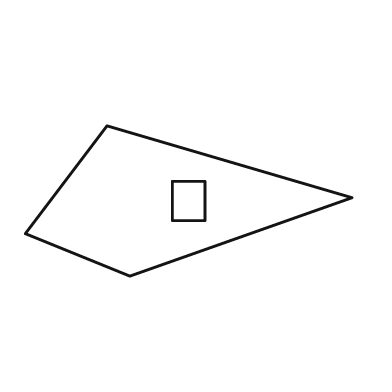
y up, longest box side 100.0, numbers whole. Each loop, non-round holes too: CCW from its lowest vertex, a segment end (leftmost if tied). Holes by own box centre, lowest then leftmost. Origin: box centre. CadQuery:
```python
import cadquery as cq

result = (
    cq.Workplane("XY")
    .moveTo(-18.0, -23.0)
    .lineTo(50.0, 1.0)
    .lineTo(-25.0, 23.0)
    .lineTo(-50.0, -10.0)
    .close()
    .moveTo(-5.0, -6.0)
    .lineTo(5.0, -6.0)
    .lineTo(5.0, 6.0)
    .lineTo(-5.0, 6.0)
    .close()
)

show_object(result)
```